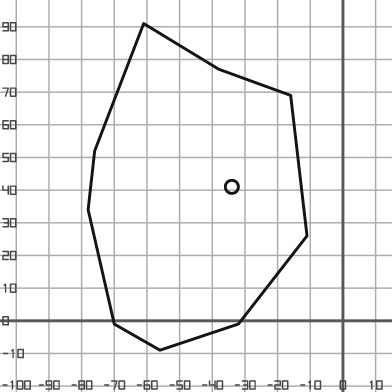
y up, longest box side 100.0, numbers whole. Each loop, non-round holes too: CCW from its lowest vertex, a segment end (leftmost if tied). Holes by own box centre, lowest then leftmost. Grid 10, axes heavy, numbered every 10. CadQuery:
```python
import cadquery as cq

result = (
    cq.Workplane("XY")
    .moveTo(-56.0, -9.0)
    .lineTo(-32.0, -1.0)
    .lineTo(-11.0, 26.0)
    .lineTo(-16.0, 69.0)
    .lineTo(-38.0, 77.0)
    .lineTo(-61.0, 91.0)
    .lineTo(-76.0, 52.0)
    .lineTo(-78.0, 34.0)
    .lineTo(-70.0, -1.0)
    .close()
    .moveTo(-34.0, 41.0)
    .circle(2.0)
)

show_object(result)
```